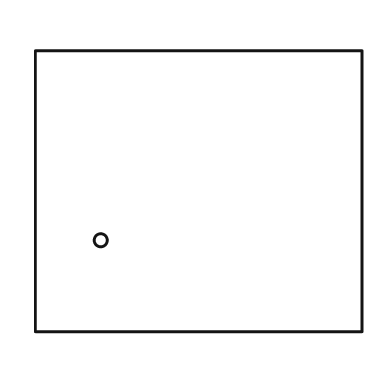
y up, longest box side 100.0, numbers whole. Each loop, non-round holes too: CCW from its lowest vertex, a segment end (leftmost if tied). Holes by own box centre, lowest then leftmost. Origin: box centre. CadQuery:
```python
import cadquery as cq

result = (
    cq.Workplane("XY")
    .moveTo(-50.0, -43.0)
    .lineTo(50.0, -43.0)
    .lineTo(50.0, 43.0)
    .lineTo(-50.0, 43.0)
    .close()
    .moveTo(-30.0, -15.0)
    .circle(2.0)
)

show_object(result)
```